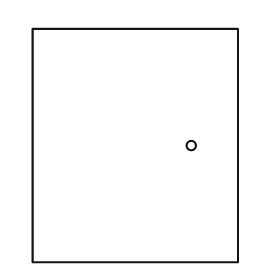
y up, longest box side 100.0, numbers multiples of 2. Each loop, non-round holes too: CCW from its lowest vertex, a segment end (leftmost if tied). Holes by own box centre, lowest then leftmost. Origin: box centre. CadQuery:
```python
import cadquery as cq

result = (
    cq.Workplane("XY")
    .moveTo(-44.0, -50.0)
    .lineTo(44.0, -50.0)
    .lineTo(44.0, 50.0)
    .lineTo(-44.0, 50.0)
    .close()
    .moveTo(24.0, 0.0)
    .circle(2.0)
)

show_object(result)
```